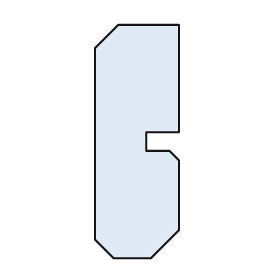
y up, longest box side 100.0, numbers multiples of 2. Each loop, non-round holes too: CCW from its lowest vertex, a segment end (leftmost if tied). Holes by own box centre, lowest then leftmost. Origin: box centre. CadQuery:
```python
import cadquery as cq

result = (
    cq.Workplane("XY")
    .moveTo(-10.0, -50.0)
    .lineTo(6.0, -50.0)
    .lineTo(18.0, -38.0)
    .lineTo(18.0, -8.0)
    .lineTo(14.0, -4.0)
    .lineTo(4.0, -4.0)
    .lineTo(4.0, 4.0)
    .lineTo(18.0, 4.0)
    .lineTo(18.0, 50.0)
    .lineTo(-8.0, 50.0)
    .lineTo(-18.0, 40.0)
    .lineTo(-18.0, -42.0)
    .close()
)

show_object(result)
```